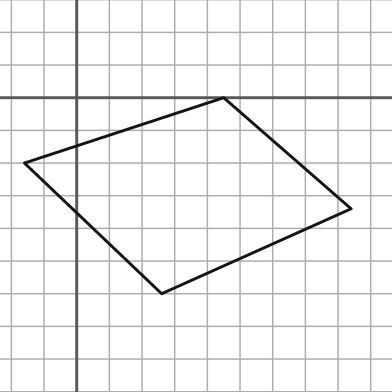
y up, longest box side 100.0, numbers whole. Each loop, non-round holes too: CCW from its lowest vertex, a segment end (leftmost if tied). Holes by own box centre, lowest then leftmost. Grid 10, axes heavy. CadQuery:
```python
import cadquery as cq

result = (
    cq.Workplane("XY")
    .moveTo(26.0, -60.0)
    .lineTo(84.0, -34.0)
    .lineTo(45.0, 0.0)
    .lineTo(-16.0, -20.0)
    .close()
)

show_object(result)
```